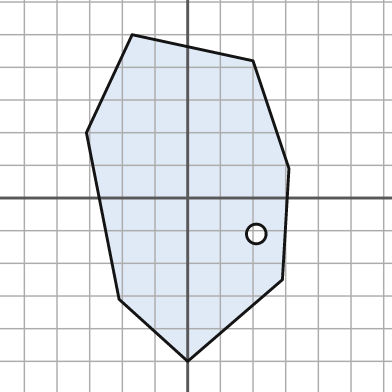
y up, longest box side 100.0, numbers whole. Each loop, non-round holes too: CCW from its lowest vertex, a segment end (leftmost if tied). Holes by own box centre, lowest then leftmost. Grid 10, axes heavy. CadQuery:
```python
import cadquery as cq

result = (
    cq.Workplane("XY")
    .moveTo(0.0, -50.0)
    .lineTo(29.0, -25.0)
    .lineTo(31.0, 9.0)
    .lineTo(20.0, 42.0)
    .lineTo(-17.0, 50.0)
    .lineTo(-31.0, 20.0)
    .lineTo(-21.0, -31.0)
    .close()
    .moveTo(21.0, -11.0)
    .circle(3.0)
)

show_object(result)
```